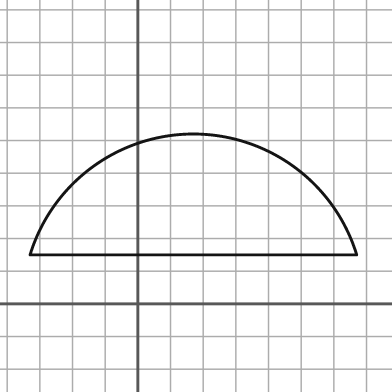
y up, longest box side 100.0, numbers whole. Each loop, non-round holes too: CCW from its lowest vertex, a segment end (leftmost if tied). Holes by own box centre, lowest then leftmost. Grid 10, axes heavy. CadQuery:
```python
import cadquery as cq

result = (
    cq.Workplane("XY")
    .moveTo(-33.0, 15.0)
    .lineTo(67.0, 15.0)
    .threePointArc((17.0, 52.0), (-33.0, 15.0))
    .close()
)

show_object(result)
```